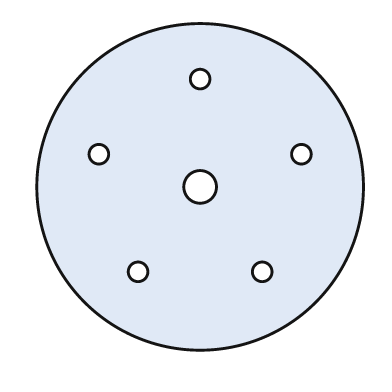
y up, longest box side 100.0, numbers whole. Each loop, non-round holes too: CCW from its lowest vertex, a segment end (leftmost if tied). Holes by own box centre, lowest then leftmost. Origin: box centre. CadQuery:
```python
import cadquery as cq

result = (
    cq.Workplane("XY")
    .moveTo(0.0, 0.0)
    .circle(50.0)
    .moveTo(-19.0, -26.0)
    .circle(3.0)
    .moveTo(19.0, -26.0)
    .circle(3.0)
    .moveTo(0.0, 0.0)
    .circle(5.0)
    .moveTo(-31.0, 10.0)
    .circle(3.0)
    .moveTo(31.0, 10.0)
    .circle(3.0)
    .moveTo(0.0, 33.0)
    .circle(3.0)
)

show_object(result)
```